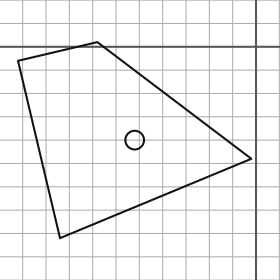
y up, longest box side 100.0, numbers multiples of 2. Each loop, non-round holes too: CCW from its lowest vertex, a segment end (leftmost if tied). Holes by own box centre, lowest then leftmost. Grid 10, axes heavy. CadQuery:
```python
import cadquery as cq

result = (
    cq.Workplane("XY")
    .moveTo(-84.0, -82.0)
    .lineTo(-2.0, -48.0)
    .lineTo(-68.0, 2.0)
    .lineTo(-102.0, -6.0)
    .close()
    .moveTo(-52.0, -40.0)
    .circle(4.0)
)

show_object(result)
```